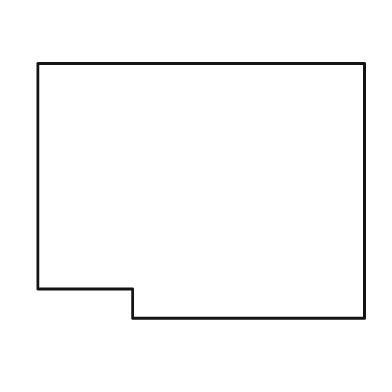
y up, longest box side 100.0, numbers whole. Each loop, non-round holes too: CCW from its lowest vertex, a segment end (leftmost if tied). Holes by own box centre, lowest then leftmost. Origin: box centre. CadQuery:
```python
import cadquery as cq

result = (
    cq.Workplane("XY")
    .moveTo(-21.0, -39.0)
    .lineTo(50.0, -39.0)
    .lineTo(50.0, 39.0)
    .lineTo(-50.0, 39.0)
    .lineTo(-50.0, -30.0)
    .lineTo(-21.0, -30.0)
    .close()
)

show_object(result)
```